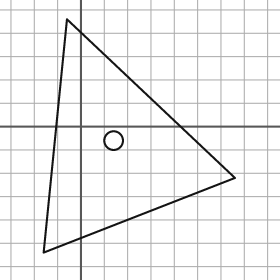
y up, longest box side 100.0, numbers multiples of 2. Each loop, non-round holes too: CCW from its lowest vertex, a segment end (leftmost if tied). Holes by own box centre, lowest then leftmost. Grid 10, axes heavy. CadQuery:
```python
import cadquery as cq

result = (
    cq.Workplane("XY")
    .moveTo(-16.0, -54.0)
    .lineTo(66.0, -22.0)
    .lineTo(-6.0, 46.0)
    .close()
    .moveTo(14.0, -6.0)
    .circle(4.0)
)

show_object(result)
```